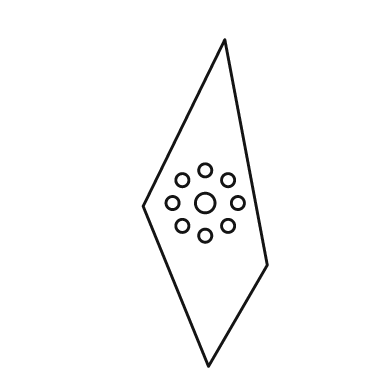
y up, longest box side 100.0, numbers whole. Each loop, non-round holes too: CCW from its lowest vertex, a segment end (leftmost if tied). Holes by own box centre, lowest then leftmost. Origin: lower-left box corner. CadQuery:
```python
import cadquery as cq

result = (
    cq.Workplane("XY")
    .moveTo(20.0, 0.0)
    .lineTo(38.0, 31.0)
    .lineTo(25.0, 100.0)
    .lineTo(0.0, 49.0)
    .close()
    .moveTo(19.0, 40.0)
    .circle(2.0)
    .moveTo(12.0, 43.0)
    .circle(2.0)
    .moveTo(26.0, 43.0)
    .circle(2.0)
    .moveTo(9.0, 50.0)
    .circle(2.0)
    .moveTo(19.0, 50.0)
    .circle(3.0)
    .moveTo(29.0, 50.0)
    .circle(2.0)
    .moveTo(12.0, 57.0)
    .circle(2.0)
    .moveTo(26.0, 57.0)
    .circle(2.0)
    .moveTo(19.0, 60.0)
    .circle(2.0)
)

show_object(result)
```